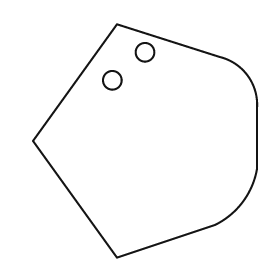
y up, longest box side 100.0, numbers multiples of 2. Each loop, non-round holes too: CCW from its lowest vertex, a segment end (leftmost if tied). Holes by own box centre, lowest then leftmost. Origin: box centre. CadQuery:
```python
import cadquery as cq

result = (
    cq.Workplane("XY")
    .moveTo(-12.0, -50.0)
    .lineTo(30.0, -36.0)
    .threePointArc((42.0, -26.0), (48.0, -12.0))
    .lineTo(48.0, 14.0)
    .threePointArc((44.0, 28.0), (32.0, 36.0))
    .lineTo(-12.0, 50.0)
    .lineTo(-48.0, 0.0)
    .close()
    .moveTo(-14.0, 26.0)
    .circle(4.0)
    .moveTo(0.0, 38.0)
    .circle(4.0)
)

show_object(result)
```